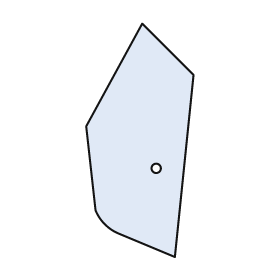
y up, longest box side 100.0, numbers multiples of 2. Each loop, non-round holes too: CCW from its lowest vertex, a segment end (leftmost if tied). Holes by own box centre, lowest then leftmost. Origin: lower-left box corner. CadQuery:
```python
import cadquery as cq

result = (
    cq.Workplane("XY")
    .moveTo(38.0, 0.0)
    .lineTo(46.0, 78.0)
    .lineTo(24.0, 100.0)
    .lineTo(0.0, 56.0)
    .lineTo(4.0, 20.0)
    .threePointArc((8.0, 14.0), (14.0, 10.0))
    .close()
    .moveTo(30.0, 38.0)
    .circle(2.0)
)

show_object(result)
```